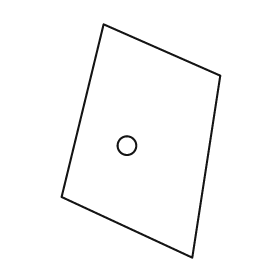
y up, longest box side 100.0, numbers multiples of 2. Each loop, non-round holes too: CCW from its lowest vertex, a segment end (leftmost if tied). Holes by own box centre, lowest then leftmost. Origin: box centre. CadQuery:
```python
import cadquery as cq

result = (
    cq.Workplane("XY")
    .moveTo(22.0, -50.0)
    .lineTo(34.0, 28.0)
    .lineTo(-16.0, 50.0)
    .lineTo(-34.0, -24.0)
    .close()
    .moveTo(-6.0, -2.0)
    .circle(4.0)
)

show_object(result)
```